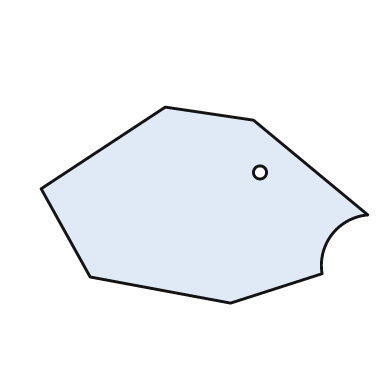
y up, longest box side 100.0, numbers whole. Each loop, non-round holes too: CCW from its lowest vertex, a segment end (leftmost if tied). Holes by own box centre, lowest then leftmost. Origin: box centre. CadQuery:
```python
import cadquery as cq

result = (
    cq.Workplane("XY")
    .moveTo(8.0, -30.0)
    .lineTo(36.0, -21.0)
    .threePointArc((39.0, -9.0), (50.0, -3.0))
    .lineTo(15.0, 26.0)
    .lineTo(-12.0, 30.0)
    .lineTo(-50.0, 5.0)
    .lineTo(-35.0, -22.0)
    .close()
    .moveTo(17.0, 10.0)
    .circle(2.0)
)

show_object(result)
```